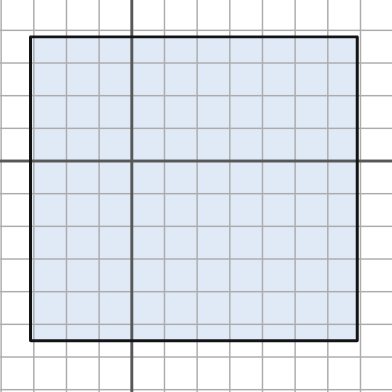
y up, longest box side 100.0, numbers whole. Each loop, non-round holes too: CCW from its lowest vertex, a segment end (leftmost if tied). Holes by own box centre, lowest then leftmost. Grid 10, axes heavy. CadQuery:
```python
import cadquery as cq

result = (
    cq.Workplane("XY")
    .moveTo(-31.0, -55.0)
    .lineTo(69.0, -55.0)
    .lineTo(69.0, 38.0)
    .lineTo(-31.0, 38.0)
    .close()
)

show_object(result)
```